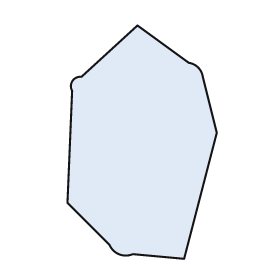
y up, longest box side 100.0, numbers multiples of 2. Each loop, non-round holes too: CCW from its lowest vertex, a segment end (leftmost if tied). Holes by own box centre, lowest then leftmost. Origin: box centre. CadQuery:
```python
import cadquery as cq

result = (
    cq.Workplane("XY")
    .moveTo(18.0, -50.0)
    .lineTo(32.0, 4.0)
    .lineTo(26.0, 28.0)
    .threePointArc((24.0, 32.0), (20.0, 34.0))
    .lineTo(-2.0, 50.0)
    .lineTo(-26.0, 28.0)
    .threePointArc((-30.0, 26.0), (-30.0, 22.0))
    .lineTo(-32.0, -26.0)
    .lineTo(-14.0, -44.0)
    .threePointArc((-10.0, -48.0), (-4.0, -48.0))
    .close()
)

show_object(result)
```